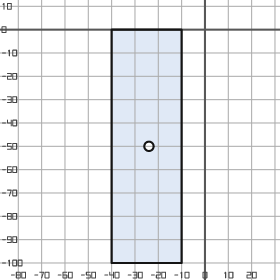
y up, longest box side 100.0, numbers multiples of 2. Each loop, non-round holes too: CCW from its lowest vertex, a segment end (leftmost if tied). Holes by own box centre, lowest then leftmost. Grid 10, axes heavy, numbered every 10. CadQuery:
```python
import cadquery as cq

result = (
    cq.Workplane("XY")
    .moveTo(-40.0, -100.0)
    .lineTo(-10.0, -100.0)
    .lineTo(-10.0, 0.0)
    .lineTo(-40.0, 0.0)
    .close()
    .moveTo(-24.0, -50.0)
    .circle(2.0)
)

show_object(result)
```